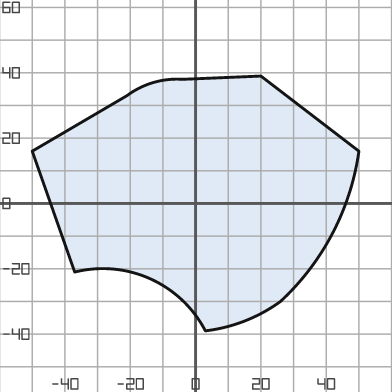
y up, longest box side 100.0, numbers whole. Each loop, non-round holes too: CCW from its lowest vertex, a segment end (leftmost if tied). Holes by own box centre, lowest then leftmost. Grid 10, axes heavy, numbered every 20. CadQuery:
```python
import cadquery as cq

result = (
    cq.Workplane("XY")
    .moveTo(3.0, -39.0)
    .threePointArc((15.0, -36.0), (26.0, -30.0))
    .threePointArc((42.0, -9.0), (50.0, 16.0))
    .lineTo(20.0, 39.0)
    .lineTo(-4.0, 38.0)
    .threePointArc((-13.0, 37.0), (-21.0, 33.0))
    .lineTo(-50.0, 16.0)
    .lineTo(-37.0, -21.0)
    .threePointArc((-14.0, -23.0), (3.0, -39.0))
    .close()
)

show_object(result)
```